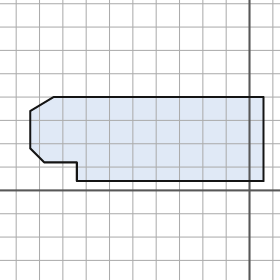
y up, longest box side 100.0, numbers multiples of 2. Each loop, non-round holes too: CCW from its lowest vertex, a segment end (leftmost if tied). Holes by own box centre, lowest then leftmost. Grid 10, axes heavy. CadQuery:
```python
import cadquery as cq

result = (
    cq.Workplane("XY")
    .moveTo(-74.0, 4.0)
    .lineTo(6.0, 4.0)
    .lineTo(6.0, 40.0)
    .lineTo(-84.0, 40.0)
    .lineTo(-94.0, 34.0)
    .lineTo(-94.0, 18.0)
    .lineTo(-88.0, 12.0)
    .lineTo(-74.0, 12.0)
    .close()
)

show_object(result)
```